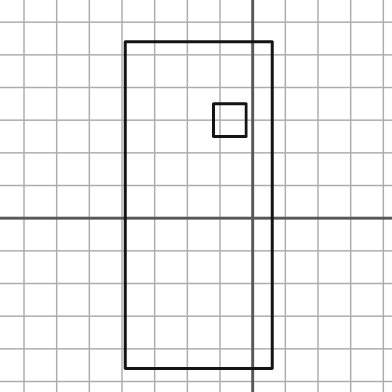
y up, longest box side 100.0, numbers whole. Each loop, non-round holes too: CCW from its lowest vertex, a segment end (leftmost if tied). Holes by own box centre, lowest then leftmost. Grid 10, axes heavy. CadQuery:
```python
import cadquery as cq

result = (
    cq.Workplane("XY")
    .moveTo(-39.0, -46.0)
    .lineTo(6.0, -46.0)
    .lineTo(6.0, 54.0)
    .lineTo(-39.0, 54.0)
    .close()
    .moveTo(-12.0, 25.0)
    .lineTo(-2.0, 25.0)
    .lineTo(-2.0, 35.0)
    .lineTo(-12.0, 35.0)
    .close()
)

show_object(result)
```